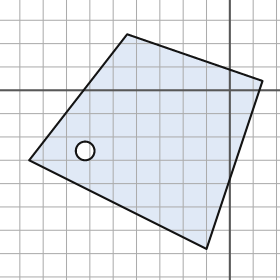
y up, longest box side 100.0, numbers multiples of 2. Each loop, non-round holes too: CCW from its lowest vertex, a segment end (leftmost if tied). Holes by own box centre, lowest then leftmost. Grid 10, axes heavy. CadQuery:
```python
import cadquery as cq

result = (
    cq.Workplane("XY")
    .moveTo(-10.0, -68.0)
    .lineTo(14.0, 4.0)
    .lineTo(-44.0, 24.0)
    .lineTo(-86.0, -30.0)
    .close()
    .moveTo(-62.0, -26.0)
    .circle(4.0)
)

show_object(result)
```